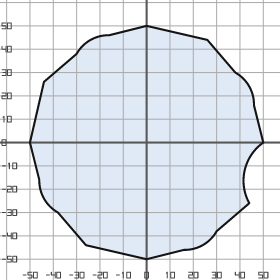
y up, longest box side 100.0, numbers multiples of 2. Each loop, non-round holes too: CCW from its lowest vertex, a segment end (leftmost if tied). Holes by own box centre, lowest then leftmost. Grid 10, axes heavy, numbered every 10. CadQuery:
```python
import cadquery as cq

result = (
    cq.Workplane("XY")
    .moveTo(0.0, -50.0)
    .lineTo(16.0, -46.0)
    .threePointArc((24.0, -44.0), (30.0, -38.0))
    .lineTo(44.0, -26.0)
    .threePointArc((42.0, -12.0), (50.0, 0.0))
    .lineTo(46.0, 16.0)
    .threePointArc((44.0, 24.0), (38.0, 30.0))
    .lineTo(26.0, 44.0)
    .lineTo(0.0, 50.0)
    .lineTo(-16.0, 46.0)
    .threePointArc((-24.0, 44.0), (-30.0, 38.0))
    .lineTo(-44.0, 26.0)
    .lineTo(-50.0, 0.0)
    .lineTo(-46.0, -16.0)
    .threePointArc((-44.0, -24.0), (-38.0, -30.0))
    .lineTo(-26.0, -44.0)
    .close()
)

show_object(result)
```